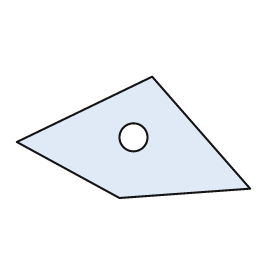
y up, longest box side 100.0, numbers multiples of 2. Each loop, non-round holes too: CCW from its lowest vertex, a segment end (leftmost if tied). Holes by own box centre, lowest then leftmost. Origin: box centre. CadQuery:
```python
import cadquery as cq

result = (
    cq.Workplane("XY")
    .moveTo(-6.0, -26.0)
    .lineTo(50.0, -22.0)
    .lineTo(8.0, 26.0)
    .lineTo(-50.0, -2.0)
    .close()
    .moveTo(0.0, 0.0)
    .circle(6.0)
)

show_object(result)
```